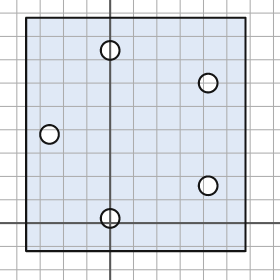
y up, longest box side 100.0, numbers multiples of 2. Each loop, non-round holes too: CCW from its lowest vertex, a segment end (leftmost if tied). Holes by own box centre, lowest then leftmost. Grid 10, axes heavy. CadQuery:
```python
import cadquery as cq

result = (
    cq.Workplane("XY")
    .moveTo(-36.0, -12.0)
    .lineTo(58.0, -12.0)
    .lineTo(58.0, 88.0)
    .lineTo(-36.0, 88.0)
    .close()
    .moveTo(0.0, 2.0)
    .circle(4.0)
    .moveTo(42.0, 16.0)
    .circle(4.0)
    .moveTo(-26.0, 38.0)
    .circle(4.0)
    .moveTo(42.0, 60.0)
    .circle(4.0)
    .moveTo(0.0, 74.0)
    .circle(4.0)
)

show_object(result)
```